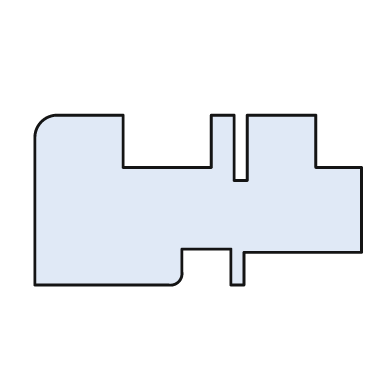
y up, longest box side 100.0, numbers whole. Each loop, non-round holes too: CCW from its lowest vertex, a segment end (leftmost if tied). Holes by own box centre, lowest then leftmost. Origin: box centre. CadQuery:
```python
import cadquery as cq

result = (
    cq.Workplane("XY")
    .moveTo(-50.0, -26.0)
    .lineTo(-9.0, -26.0)
    .threePointArc((-6.0, -25.0), (-5.0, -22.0))
    .lineTo(-5.0, -15.0)
    .lineTo(10.0, -15.0)
    .lineTo(10.0, -26.0)
    .lineTo(14.0, -26.0)
    .lineTo(14.0, -16.0)
    .lineTo(50.0, -16.0)
    .lineTo(50.0, 10.0)
    .lineTo(36.0, 10.0)
    .lineTo(36.0, 26.0)
    .lineTo(15.0, 26.0)
    .lineTo(15.0, 6.0)
    .lineTo(11.0, 6.0)
    .lineTo(11.0, 26.0)
    .lineTo(4.0, 26.0)
    .lineTo(4.0, 10.0)
    .lineTo(-23.0, 10.0)
    .lineTo(-23.0, 26.0)
    .lineTo(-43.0, 26.0)
    .threePointArc((-48.0, 24.0), (-50.0, 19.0))
    .close()
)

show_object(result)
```